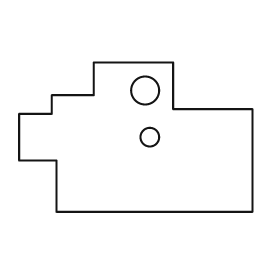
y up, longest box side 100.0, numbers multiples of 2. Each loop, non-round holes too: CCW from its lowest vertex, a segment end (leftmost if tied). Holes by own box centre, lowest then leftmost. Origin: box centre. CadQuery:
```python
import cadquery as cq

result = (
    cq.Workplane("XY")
    .moveTo(-34.0, -32.0)
    .lineTo(50.0, -32.0)
    .lineTo(50.0, 12.0)
    .lineTo(16.0, 12.0)
    .lineTo(16.0, 32.0)
    .lineTo(-18.0, 32.0)
    .lineTo(-18.0, 18.0)
    .lineTo(-36.0, 18.0)
    .lineTo(-36.0, 10.0)
    .lineTo(-50.0, 10.0)
    .lineTo(-50.0, -10.0)
    .lineTo(-34.0, -10.0)
    .close()
    .moveTo(6.0, 0.0)
    .circle(4.0)
    .moveTo(4.0, 20.0)
    .circle(6.0)
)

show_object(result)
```